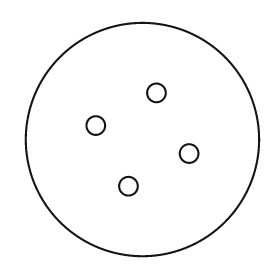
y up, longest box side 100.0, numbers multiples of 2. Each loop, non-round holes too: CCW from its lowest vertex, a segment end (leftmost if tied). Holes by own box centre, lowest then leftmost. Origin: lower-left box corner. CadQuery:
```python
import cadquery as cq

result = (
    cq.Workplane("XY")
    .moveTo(50.0, 50.0)
    .circle(50.0)
    .moveTo(44.0, 30.0)
    .circle(4.0)
    .moveTo(70.0, 44.0)
    .circle(4.0)
    .moveTo(30.0, 56.0)
    .circle(4.0)
    .moveTo(56.0, 70.0)
    .circle(4.0)
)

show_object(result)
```